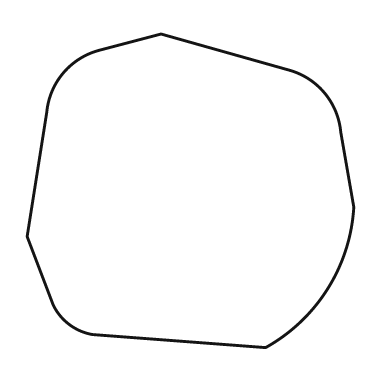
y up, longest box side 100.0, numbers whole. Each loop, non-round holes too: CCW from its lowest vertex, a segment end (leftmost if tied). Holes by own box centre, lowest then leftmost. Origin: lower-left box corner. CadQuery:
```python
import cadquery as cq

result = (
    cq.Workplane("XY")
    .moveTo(73.0, 0.0)
    .threePointArc((92.0, 18.0), (100.0, 43.0))
    .lineTo(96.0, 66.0)
    .threePointArc((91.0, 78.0), (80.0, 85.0))
    .lineTo(41.0, 96.0)
    .lineTo(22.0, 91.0)
    .threePointArc((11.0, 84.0), (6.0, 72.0))
    .lineTo(0.0, 34.0)
    .lineTo(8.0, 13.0)
    .threePointArc((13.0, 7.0), (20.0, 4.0))
    .close()
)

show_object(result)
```